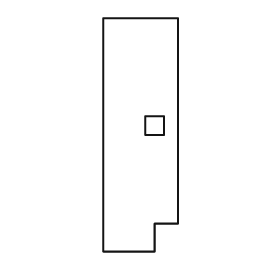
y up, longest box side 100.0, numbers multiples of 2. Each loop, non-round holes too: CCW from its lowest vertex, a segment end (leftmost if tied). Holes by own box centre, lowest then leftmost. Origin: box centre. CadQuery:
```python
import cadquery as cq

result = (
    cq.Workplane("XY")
    .moveTo(-16.0, -50.0)
    .lineTo(6.0, -50.0)
    .lineTo(6.0, -38.0)
    .lineTo(16.0, -38.0)
    .lineTo(16.0, 50.0)
    .lineTo(-16.0, 50.0)
    .close()
    .moveTo(2.0, 0.0)
    .lineTo(10.0, 0.0)
    .lineTo(10.0, 8.0)
    .lineTo(2.0, 8.0)
    .close()
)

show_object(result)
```